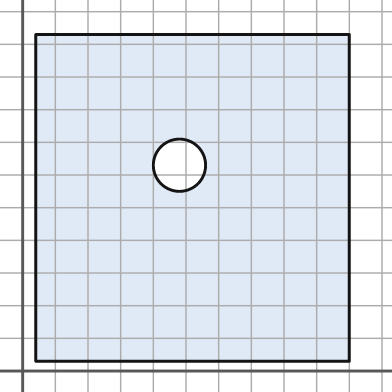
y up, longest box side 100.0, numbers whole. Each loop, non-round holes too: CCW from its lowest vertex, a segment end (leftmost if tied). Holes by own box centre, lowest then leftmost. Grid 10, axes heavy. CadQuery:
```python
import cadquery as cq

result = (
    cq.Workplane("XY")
    .moveTo(4.0, 3.0)
    .lineTo(100.0, 3.0)
    .lineTo(100.0, 103.0)
    .lineTo(4.0, 103.0)
    .close()
    .moveTo(48.0, 63.0)
    .circle(8.0)
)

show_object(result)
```